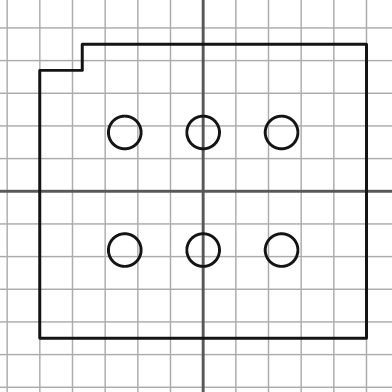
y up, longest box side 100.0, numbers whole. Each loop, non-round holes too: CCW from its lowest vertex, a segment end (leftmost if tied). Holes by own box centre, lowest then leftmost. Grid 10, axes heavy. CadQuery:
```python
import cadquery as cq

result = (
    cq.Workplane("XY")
    .moveTo(-50.0, -45.0)
    .lineTo(50.0, -45.0)
    .lineTo(50.0, 45.0)
    .lineTo(-37.0, 45.0)
    .lineTo(-37.0, 37.0)
    .lineTo(-50.0, 37.0)
    .close()
    .moveTo(-24.0, -18.0)
    .circle(5.0)
    .moveTo(0.0, -18.0)
    .circle(5.0)
    .moveTo(24.0, -18.0)
    .circle(5.0)
    .moveTo(-24.0, 18.0)
    .circle(5.0)
    .moveTo(0.0, 18.0)
    .circle(5.0)
    .moveTo(24.0, 18.0)
    .circle(5.0)
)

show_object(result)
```